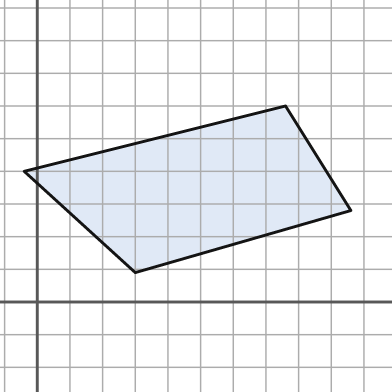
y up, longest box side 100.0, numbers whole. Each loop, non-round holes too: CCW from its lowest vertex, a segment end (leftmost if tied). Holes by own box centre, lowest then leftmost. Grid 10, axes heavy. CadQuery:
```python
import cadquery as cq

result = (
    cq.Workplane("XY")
    .moveTo(30.0, 9.0)
    .lineTo(96.0, 28.0)
    .lineTo(76.0, 60.0)
    .lineTo(-4.0, 40.0)
    .close()
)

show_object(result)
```